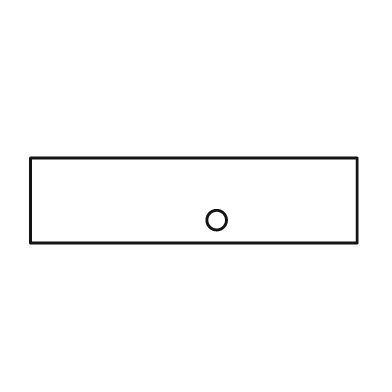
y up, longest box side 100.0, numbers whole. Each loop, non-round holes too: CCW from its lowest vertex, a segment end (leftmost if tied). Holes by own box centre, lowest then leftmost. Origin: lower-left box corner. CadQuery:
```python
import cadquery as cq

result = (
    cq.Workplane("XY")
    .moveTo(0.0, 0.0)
    .lineTo(100.0, 0.0)
    .lineTo(100.0, 26.0)
    .lineTo(0.0, 26.0)
    .close()
    .moveTo(57.0, 7.0)
    .circle(3.0)
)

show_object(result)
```